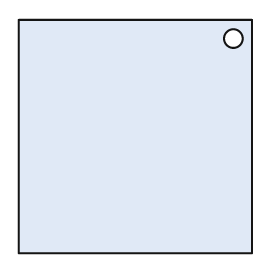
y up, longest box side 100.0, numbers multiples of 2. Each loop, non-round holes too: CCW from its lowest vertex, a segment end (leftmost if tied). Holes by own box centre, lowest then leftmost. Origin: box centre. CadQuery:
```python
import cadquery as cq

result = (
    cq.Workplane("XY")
    .moveTo(-50.0, -50.0)
    .lineTo(50.0, -50.0)
    .lineTo(50.0, 50.0)
    .lineTo(-50.0, 50.0)
    .close()
    .moveTo(42.0, 42.0)
    .circle(4.0)
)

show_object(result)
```